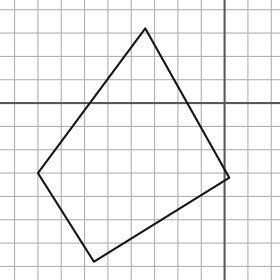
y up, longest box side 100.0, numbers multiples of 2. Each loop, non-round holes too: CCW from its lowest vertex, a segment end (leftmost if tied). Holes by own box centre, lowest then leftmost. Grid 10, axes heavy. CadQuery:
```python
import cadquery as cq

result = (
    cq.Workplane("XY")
    .moveTo(-56.0, -68.0)
    .lineTo(2.0, -32.0)
    .lineTo(-34.0, 32.0)
    .lineTo(-80.0, -30.0)
    .close()
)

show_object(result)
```